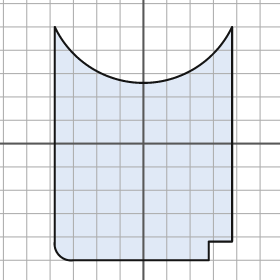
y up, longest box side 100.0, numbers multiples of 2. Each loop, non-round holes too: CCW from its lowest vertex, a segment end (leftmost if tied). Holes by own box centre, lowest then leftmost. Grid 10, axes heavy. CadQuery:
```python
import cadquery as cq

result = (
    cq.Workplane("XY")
    .moveTo(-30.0, -50.0)
    .lineTo(28.0, -50.0)
    .lineTo(28.0, -42.0)
    .lineTo(38.0, -42.0)
    .lineTo(38.0, 50.0)
    .threePointArc((0.0, 26.0), (-38.0, 50.0))
    .lineTo(-38.0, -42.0)
    .threePointArc((-36.0, -48.0), (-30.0, -50.0))
    .close()
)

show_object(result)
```